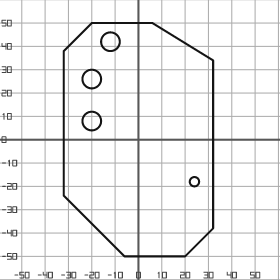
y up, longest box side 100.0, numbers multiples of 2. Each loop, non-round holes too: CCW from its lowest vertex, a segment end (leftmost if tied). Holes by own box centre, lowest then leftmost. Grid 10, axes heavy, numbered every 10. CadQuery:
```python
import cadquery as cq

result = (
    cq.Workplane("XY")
    .moveTo(-6.0, -50.0)
    .lineTo(20.0, -50.0)
    .lineTo(32.0, -38.0)
    .lineTo(32.0, 34.0)
    .lineTo(6.0, 50.0)
    .lineTo(-20.0, 50.0)
    .lineTo(-32.0, 38.0)
    .lineTo(-32.0, -24.0)
    .close()
    .moveTo(24.0, -18.0)
    .circle(2.0)
    .moveTo(-20.0, 8.0)
    .circle(4.0)
    .moveTo(-20.0, 26.0)
    .circle(4.0)
    .moveTo(-12.0, 42.0)
    .circle(4.0)
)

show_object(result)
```